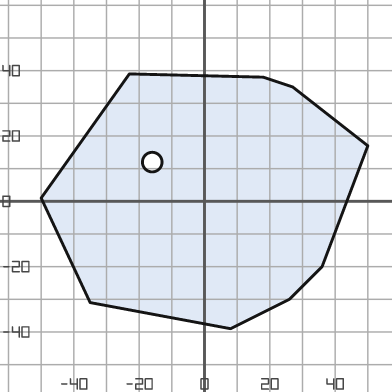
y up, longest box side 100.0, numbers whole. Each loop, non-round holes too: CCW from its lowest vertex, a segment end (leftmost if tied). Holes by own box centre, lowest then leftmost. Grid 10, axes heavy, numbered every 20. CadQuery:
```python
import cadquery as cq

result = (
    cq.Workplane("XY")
    .moveTo(8.0, -39.0)
    .lineTo(26.0, -30.0)
    .lineTo(36.0, -20.0)
    .lineTo(50.0, 17.0)
    .lineTo(27.0, 35.0)
    .lineTo(18.0, 38.0)
    .lineTo(-23.0, 39.0)
    .lineTo(-50.0, 1.0)
    .lineTo(-35.0, -31.0)
    .close()
    .moveTo(-16.0, 12.0)
    .circle(3.0)
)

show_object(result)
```